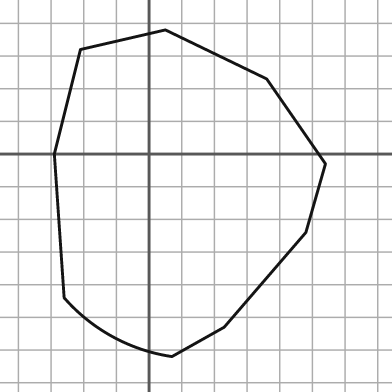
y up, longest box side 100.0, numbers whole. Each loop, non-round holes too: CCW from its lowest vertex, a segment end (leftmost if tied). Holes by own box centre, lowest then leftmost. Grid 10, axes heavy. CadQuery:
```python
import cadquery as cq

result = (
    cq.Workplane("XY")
    .moveTo(7.0, -62.0)
    .lineTo(23.0, -53.0)
    .lineTo(48.0, -24.0)
    .lineTo(54.0, -3.0)
    .lineTo(36.0, 23.0)
    .lineTo(5.0, 38.0)
    .lineTo(-21.0, 32.0)
    .lineTo(-29.0, 0.0)
    .lineTo(-26.0, -44.0)
    .threePointArc((-11.0, -56.0), (7.0, -62.0))
    .close()
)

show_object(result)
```